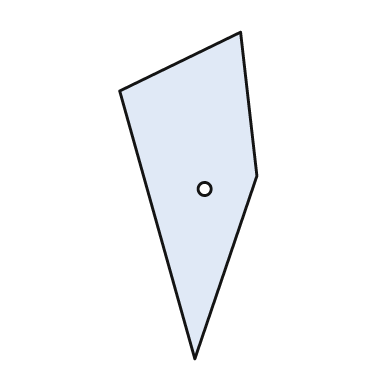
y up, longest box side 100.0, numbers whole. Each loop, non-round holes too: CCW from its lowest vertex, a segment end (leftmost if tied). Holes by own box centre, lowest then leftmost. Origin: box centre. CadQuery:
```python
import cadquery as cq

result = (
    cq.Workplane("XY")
    .moveTo(2.0, -50.0)
    .lineTo(21.0, 6.0)
    .lineTo(16.0, 50.0)
    .lineTo(-21.0, 32.0)
    .close()
    .moveTo(5.0, 2.0)
    .circle(2.0)
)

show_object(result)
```